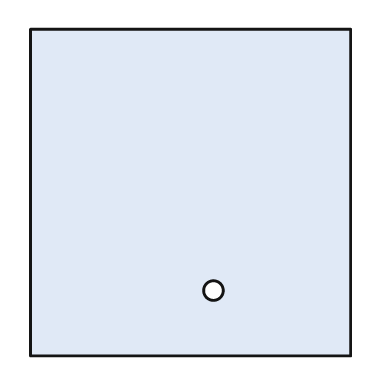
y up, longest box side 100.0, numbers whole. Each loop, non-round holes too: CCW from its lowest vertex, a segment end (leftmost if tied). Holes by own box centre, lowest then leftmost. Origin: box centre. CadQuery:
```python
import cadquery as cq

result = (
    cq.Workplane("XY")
    .moveTo(-49.0, -50.0)
    .lineTo(49.0, -50.0)
    .lineTo(49.0, 50.0)
    .lineTo(-49.0, 50.0)
    .close()
    .moveTo(7.0, -30.0)
    .circle(3.0)
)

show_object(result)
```